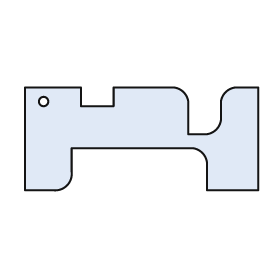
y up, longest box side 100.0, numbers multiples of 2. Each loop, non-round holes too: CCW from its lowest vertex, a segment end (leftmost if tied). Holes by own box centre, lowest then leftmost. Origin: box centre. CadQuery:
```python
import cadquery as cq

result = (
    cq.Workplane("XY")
    .moveTo(-50.0, -22.0)
    .lineTo(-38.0, -22.0)
    .threePointArc((-32.0, -20.0), (-30.0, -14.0))
    .lineTo(-30.0, -4.0)
    .lineTo(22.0, -4.0)
    .threePointArc((26.0, -6.0), (28.0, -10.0))
    .lineTo(28.0, -22.0)
    .lineTo(50.0, -22.0)
    .lineTo(50.0, 22.0)
    .lineTo(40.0, 22.0)
    .threePointArc((36.0, 20.0), (34.0, 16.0))
    .lineTo(34.0, 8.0)
    .threePointArc((32.0, 4.0), (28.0, 2.0))
    .lineTo(20.0, 2.0)
    .lineTo(20.0, 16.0)
    .threePointArc((18.0, 20.0), (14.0, 22.0))
    .lineTo(-12.0, 22.0)
    .lineTo(-12.0, 14.0)
    .lineTo(-26.0, 14.0)
    .lineTo(-26.0, 22.0)
    .lineTo(-50.0, 22.0)
    .close()
    .moveTo(-42.0, 16.0)
    .circle(2.0)
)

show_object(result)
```